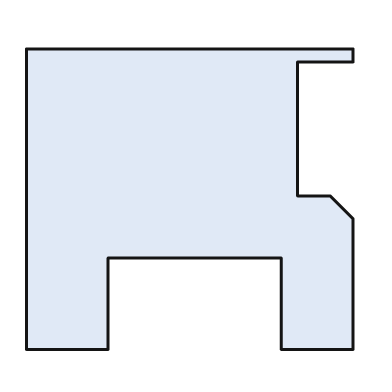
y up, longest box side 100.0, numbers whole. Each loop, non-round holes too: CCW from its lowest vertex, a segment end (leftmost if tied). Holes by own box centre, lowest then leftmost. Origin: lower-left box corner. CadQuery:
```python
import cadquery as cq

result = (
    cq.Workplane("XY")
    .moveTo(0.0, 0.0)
    .lineTo(25.0, 0.0)
    .lineTo(25.0, 28.0)
    .lineTo(78.0, 28.0)
    .lineTo(78.0, 0.0)
    .lineTo(100.0, 0.0)
    .lineTo(100.0, 40.0)
    .lineTo(93.0, 47.0)
    .lineTo(83.0, 47.0)
    .lineTo(83.0, 88.0)
    .lineTo(100.0, 88.0)
    .lineTo(100.0, 92.0)
    .lineTo(0.0, 92.0)
    .close()
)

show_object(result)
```